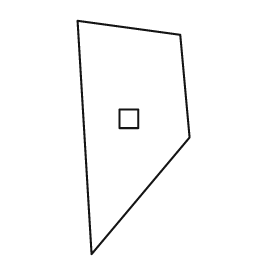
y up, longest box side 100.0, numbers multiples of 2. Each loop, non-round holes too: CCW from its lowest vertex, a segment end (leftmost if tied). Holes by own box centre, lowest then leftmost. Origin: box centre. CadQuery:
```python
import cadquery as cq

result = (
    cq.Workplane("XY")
    .moveTo(-18.0, -50.0)
    .lineTo(24.0, 0.0)
    .lineTo(20.0, 44.0)
    .lineTo(-24.0, 50.0)
    .close()
    .moveTo(-6.0, 4.0)
    .lineTo(2.0, 4.0)
    .lineTo(2.0, 12.0)
    .lineTo(-6.0, 12.0)
    .close()
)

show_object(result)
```